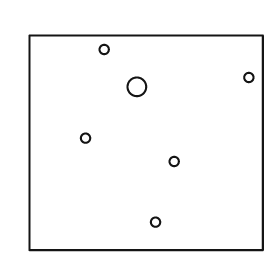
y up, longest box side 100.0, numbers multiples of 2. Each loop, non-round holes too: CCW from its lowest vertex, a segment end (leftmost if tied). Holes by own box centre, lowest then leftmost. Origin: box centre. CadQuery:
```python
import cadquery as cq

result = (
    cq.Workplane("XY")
    .moveTo(-50.0, -46.0)
    .lineTo(50.0, -46.0)
    .lineTo(50.0, 46.0)
    .lineTo(-50.0, 46.0)
    .close()
    .moveTo(4.0, -34.0)
    .circle(2.0)
    .moveTo(12.0, -8.0)
    .circle(2.0)
    .moveTo(-26.0, 2.0)
    .circle(2.0)
    .moveTo(-4.0, 24.0)
    .circle(4.0)
    .moveTo(44.0, 28.0)
    .circle(2.0)
    .moveTo(-18.0, 40.0)
    .circle(2.0)
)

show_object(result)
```